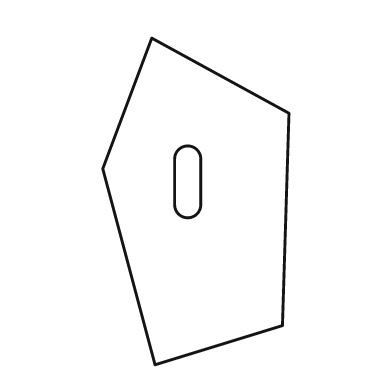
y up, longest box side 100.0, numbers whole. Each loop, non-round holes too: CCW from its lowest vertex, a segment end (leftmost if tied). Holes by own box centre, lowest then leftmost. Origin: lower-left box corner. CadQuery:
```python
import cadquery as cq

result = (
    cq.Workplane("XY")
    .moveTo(16.0, 0.0)
    .lineTo(55.0, 12.0)
    .lineTo(57.0, 77.0)
    .lineTo(15.0, 100.0)
    .lineTo(0.0, 60.0)
    .close()
    .moveTo(22.0, 49.0)
    .threePointArc((26.0, 45.0), (30.0, 49.0))
    .lineTo(30.0, 63.0)
    .threePointArc((26.0, 67.0), (22.0, 63.0))
    .close()
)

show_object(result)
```